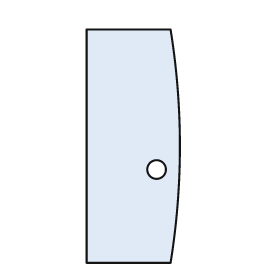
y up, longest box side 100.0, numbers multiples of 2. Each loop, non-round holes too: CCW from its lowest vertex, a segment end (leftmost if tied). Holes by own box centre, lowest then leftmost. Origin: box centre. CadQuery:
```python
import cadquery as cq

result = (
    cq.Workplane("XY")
    .moveTo(-20.0, -50.0)
    .lineTo(16.0, -50.0)
    .threePointArc((20.0, 0.0), (16.0, 50.0))
    .lineTo(-20.0, 50.0)
    .close()
    .moveTo(10.0, -10.0)
    .circle(4.0)
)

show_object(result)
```